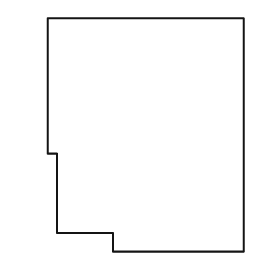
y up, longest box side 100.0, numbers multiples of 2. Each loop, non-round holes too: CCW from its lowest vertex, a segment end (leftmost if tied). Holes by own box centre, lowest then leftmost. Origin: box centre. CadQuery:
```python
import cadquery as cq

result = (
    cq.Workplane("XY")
    .moveTo(-14.0, -50.0)
    .lineTo(42.0, -50.0)
    .lineTo(42.0, 50.0)
    .lineTo(-42.0, 50.0)
    .lineTo(-42.0, -8.0)
    .lineTo(-38.0, -8.0)
    .lineTo(-38.0, -42.0)
    .lineTo(-14.0, -42.0)
    .close()
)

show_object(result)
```